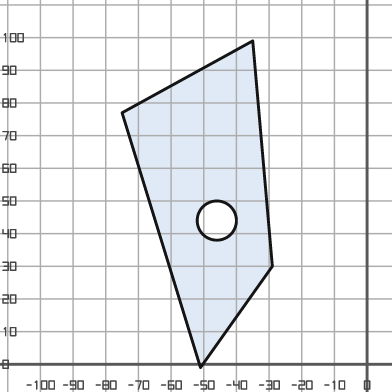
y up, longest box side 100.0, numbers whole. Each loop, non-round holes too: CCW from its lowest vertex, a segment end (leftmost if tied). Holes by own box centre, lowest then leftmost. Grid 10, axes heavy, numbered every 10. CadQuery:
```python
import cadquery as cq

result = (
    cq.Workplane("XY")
    .moveTo(-51.0, -1.0)
    .lineTo(-29.0, 30.0)
    .lineTo(-35.0, 99.0)
    .lineTo(-75.0, 77.0)
    .close()
    .moveTo(-46.0, 44.0)
    .circle(6.0)
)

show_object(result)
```